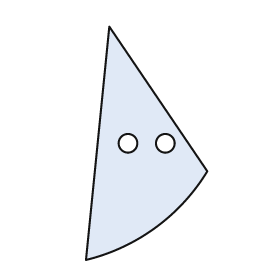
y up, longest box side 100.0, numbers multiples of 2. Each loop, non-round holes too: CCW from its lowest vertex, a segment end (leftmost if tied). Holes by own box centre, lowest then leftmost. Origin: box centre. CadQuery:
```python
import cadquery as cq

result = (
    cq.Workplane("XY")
    .moveTo(-26.0, -50.0)
    .threePointArc((4.0, -36.0), (26.0, -12.0))
    .lineTo(-16.0, 50.0)
    .close()
    .moveTo(-8.0, 0.0)
    .circle(4.0)
    .moveTo(8.0, 0.0)
    .circle(4.0)
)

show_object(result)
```